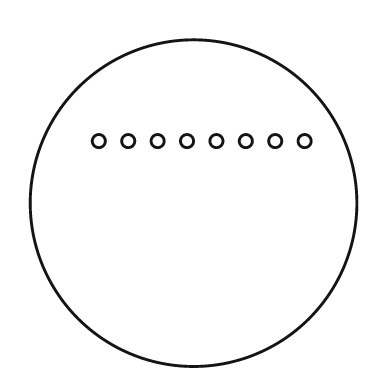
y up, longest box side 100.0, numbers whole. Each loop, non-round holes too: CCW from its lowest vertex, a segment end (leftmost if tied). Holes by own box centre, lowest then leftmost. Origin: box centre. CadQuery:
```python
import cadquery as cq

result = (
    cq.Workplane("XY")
    .moveTo(0.0, 0.0)
    .circle(50.0)
    .moveTo(-29.0, 19.0)
    .circle(2.0)
    .moveTo(-20.0, 19.0)
    .circle(2.0)
    .moveTo(-11.0, 19.0)
    .circle(2.0)
    .moveTo(-2.0, 19.0)
    .circle(2.0)
    .moveTo(7.0, 19.0)
    .circle(2.0)
    .moveTo(16.0, 19.0)
    .circle(2.0)
    .moveTo(25.0, 19.0)
    .circle(2.0)
    .moveTo(34.0, 19.0)
    .circle(2.0)
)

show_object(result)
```